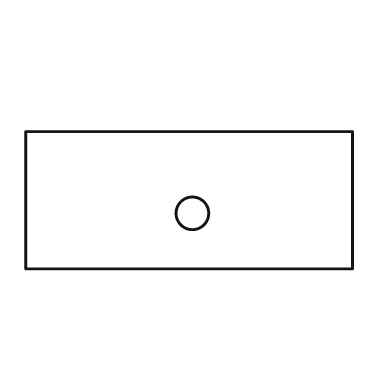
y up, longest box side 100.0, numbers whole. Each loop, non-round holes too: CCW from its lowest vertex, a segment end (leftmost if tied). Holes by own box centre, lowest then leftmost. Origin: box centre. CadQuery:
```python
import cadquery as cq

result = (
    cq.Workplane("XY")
    .moveTo(-50.0, -21.0)
    .lineTo(50.0, -21.0)
    .lineTo(50.0, 21.0)
    .lineTo(-50.0, 21.0)
    .close()
    .moveTo(1.0, -4.0)
    .circle(5.0)
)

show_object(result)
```